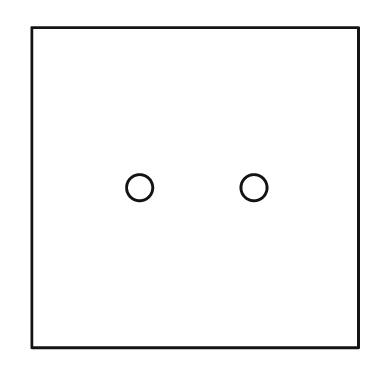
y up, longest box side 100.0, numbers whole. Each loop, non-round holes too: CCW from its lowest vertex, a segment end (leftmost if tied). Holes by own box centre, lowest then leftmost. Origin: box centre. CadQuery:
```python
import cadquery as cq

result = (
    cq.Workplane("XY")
    .moveTo(-50.0, -49.0)
    .lineTo(50.0, -49.0)
    .lineTo(50.0, 49.0)
    .lineTo(-50.0, 49.0)
    .close()
    .moveTo(-17.0, 0.0)
    .circle(4.0)
    .moveTo(18.0, 0.0)
    .circle(4.0)
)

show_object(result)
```